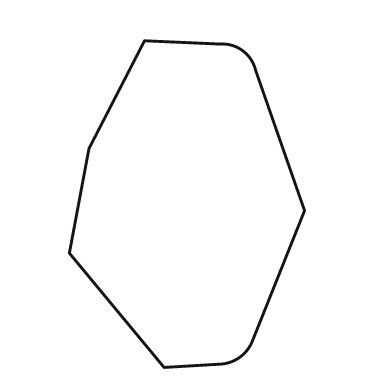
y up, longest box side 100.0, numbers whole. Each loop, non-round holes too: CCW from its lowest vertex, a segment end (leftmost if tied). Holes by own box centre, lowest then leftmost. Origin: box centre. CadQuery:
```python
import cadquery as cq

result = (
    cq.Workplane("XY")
    .moveTo(-7.0, -50.0)
    .lineTo(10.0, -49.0)
    .threePointArc((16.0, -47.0), (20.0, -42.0))
    .lineTo(36.0, -2.0)
    .lineTo(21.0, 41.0)
    .threePointArc((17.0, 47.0), (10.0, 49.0))
    .lineTo(-13.0, 50.0)
    .lineTo(-30.0, 17.0)
    .lineTo(-36.0, -15.0)
    .close()
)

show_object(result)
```